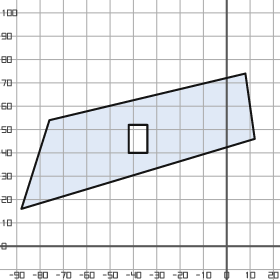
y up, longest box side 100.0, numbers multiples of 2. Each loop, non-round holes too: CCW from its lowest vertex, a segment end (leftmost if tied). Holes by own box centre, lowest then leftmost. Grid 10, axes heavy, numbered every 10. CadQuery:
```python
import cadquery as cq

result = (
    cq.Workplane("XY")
    .moveTo(-88.0, 16.0)
    .lineTo(12.0, 46.0)
    .lineTo(8.0, 74.0)
    .lineTo(-76.0, 54.0)
    .close()
    .moveTo(-42.0, 40.0)
    .lineTo(-34.0, 40.0)
    .lineTo(-34.0, 52.0)
    .lineTo(-42.0, 52.0)
    .close()
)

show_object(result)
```